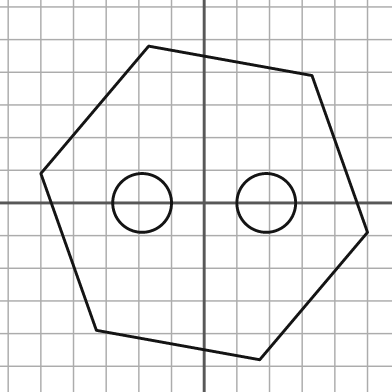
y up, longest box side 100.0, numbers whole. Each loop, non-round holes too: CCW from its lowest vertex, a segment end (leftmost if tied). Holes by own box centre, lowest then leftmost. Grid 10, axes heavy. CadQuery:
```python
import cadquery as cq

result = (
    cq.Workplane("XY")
    .moveTo(17.0, -48.0)
    .lineTo(50.0, -9.0)
    .lineTo(33.0, 39.0)
    .lineTo(-17.0, 48.0)
    .lineTo(-50.0, 9.0)
    .lineTo(-33.0, -39.0)
    .close()
    .moveTo(-19.0, 0.0)
    .circle(9.0)
    .moveTo(19.0, 0.0)
    .circle(9.0)
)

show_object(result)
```